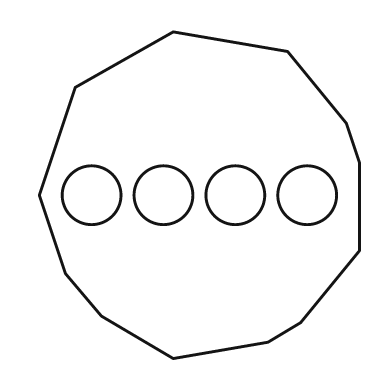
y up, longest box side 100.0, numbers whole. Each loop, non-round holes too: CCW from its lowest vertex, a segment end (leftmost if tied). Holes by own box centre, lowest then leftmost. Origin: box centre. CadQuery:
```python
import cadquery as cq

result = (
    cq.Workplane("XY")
    .moveTo(-8.0, -50.0)
    .lineTo(21.0, -45.0)
    .lineTo(31.0, -39.0)
    .lineTo(49.0, -17.0)
    .lineTo(49.0, 10.0)
    .lineTo(45.0, 22.0)
    .lineTo(27.0, 44.0)
    .lineTo(-8.0, 50.0)
    .lineTo(-38.0, 33.0)
    .lineTo(-49.0, 0.0)
    .lineTo(-41.0, -24.0)
    .lineTo(-30.0, -37.0)
    .close()
    .moveTo(-33.0, 0.0)
    .circle(9.0)
    .moveTo(-11.0, 0.0)
    .circle(9.0)
    .moveTo(11.0, 0.0)
    .circle(9.0)
    .moveTo(33.0, 0.0)
    .circle(9.0)
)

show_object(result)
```